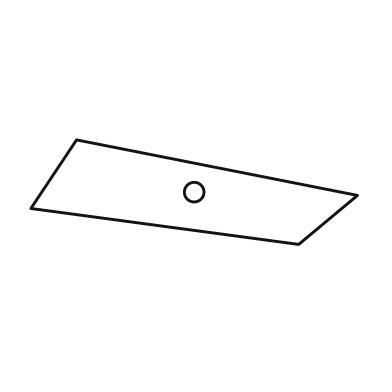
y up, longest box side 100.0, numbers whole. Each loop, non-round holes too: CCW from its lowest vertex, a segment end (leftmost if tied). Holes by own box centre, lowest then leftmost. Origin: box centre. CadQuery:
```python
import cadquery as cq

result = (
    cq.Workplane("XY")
    .moveTo(32.0, -16.0)
    .lineTo(50.0, -1.0)
    .lineTo(-36.0, 16.0)
    .lineTo(-50.0, -5.0)
    .close()
    .moveTo(0.0, 0.0)
    .circle(3.0)
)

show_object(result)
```